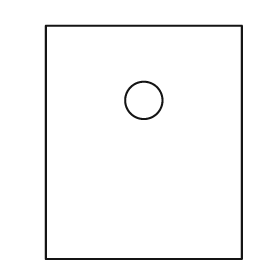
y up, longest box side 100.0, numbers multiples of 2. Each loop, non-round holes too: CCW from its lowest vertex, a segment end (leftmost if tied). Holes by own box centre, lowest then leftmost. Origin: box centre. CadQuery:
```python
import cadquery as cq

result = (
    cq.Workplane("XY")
    .moveTo(-42.0, -50.0)
    .lineTo(42.0, -50.0)
    .lineTo(42.0, 50.0)
    .lineTo(-42.0, 50.0)
    .close()
    .moveTo(0.0, 18.0)
    .circle(8.0)
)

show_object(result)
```